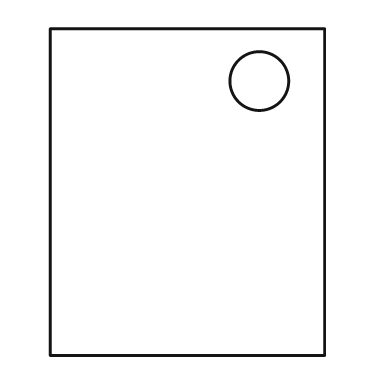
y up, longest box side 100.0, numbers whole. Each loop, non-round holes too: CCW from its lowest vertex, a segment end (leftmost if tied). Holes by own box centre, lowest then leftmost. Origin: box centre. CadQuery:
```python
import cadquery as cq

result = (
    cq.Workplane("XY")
    .moveTo(-42.0, -50.0)
    .lineTo(42.0, -50.0)
    .lineTo(42.0, 50.0)
    .lineTo(-42.0, 50.0)
    .close()
    .moveTo(22.0, 34.0)
    .circle(9.0)
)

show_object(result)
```